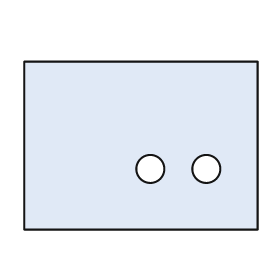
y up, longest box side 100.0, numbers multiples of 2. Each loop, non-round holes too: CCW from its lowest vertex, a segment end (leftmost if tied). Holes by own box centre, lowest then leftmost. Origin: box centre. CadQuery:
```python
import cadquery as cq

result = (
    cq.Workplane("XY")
    .moveTo(-50.0, -36.0)
    .lineTo(50.0, -36.0)
    .lineTo(50.0, 36.0)
    .lineTo(-50.0, 36.0)
    .close()
    .moveTo(4.0, -10.0)
    .circle(6.0)
    .moveTo(28.0, -10.0)
    .circle(6.0)
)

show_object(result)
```